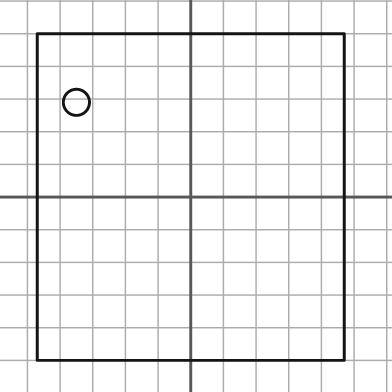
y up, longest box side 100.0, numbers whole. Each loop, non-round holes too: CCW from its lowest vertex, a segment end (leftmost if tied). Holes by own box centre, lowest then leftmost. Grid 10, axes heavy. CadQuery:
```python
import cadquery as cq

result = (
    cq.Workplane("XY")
    .moveTo(-47.0, -50.0)
    .lineTo(47.0, -50.0)
    .lineTo(47.0, 50.0)
    .lineTo(-47.0, 50.0)
    .close()
    .moveTo(-35.0, 29.0)
    .circle(4.0)
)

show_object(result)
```